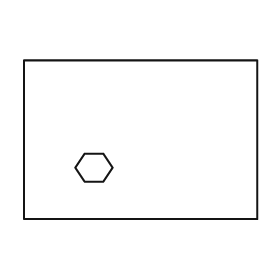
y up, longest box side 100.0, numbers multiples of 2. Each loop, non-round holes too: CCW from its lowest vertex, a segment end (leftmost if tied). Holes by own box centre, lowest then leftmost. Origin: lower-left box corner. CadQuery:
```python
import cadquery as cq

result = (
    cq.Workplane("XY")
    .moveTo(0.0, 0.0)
    .lineTo(100.0, 0.0)
    .lineTo(100.0, 68.0)
    .lineTo(0.0, 68.0)
    .close()
    .moveTo(26.0, 16.0)
    .lineTo(34.0, 16.0)
    .lineTo(38.0, 22.0)
    .lineTo(34.0, 28.0)
    .lineTo(26.0, 28.0)
    .lineTo(22.0, 22.0)
    .close()
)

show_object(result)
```